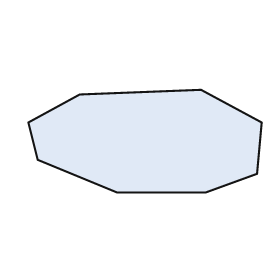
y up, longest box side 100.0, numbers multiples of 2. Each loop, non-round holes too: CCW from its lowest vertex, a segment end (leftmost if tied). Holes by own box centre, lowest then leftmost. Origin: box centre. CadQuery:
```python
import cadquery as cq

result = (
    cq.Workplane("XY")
    .moveTo(-12.0, -22.0)
    .lineTo(26.0, -22.0)
    .lineTo(48.0, -14.0)
    .lineTo(50.0, 8.0)
    .lineTo(24.0, 22.0)
    .lineTo(-28.0, 20.0)
    .lineTo(-50.0, 8.0)
    .lineTo(-46.0, -8.0)
    .close()
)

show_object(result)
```